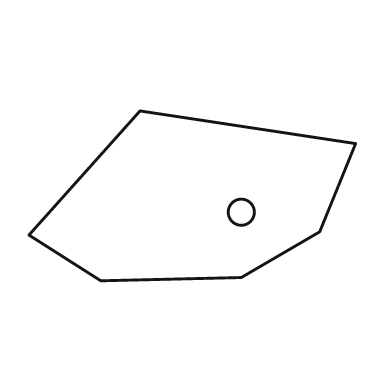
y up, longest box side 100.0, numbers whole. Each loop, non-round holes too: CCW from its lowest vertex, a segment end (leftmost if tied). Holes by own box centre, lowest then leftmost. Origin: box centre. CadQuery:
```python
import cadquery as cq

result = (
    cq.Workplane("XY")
    .moveTo(-28.0, -26.0)
    .lineTo(15.0, -25.0)
    .lineTo(39.0, -11.0)
    .lineTo(50.0, 16.0)
    .lineTo(-16.0, 26.0)
    .lineTo(-50.0, -12.0)
    .close()
    .moveTo(15.0, -5.0)
    .circle(4.0)
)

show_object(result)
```